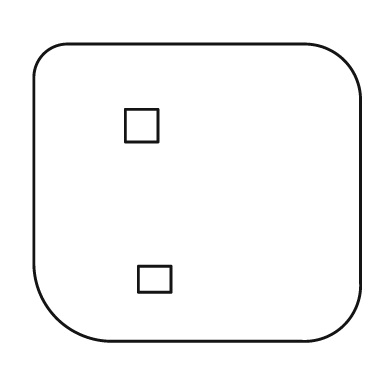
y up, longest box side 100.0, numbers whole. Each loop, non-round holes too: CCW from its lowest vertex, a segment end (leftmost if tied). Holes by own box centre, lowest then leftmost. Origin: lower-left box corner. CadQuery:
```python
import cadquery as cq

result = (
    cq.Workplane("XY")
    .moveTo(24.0, 0.0)
    .lineTo(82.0, 0.0)
    .threePointArc((95.0, 5.0), (100.0, 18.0))
    .lineTo(100.0, 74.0)
    .threePointArc((95.0, 86.0), (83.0, 91.0))
    .lineTo(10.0, 91.0)
    .threePointArc((3.0, 88.0), (0.0, 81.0))
    .lineTo(0.0, 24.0)
    .threePointArc((7.0, 7.0), (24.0, 0.0))
    .close()
    .moveTo(32.0, 15.0)
    .lineTo(42.0, 15.0)
    .lineTo(42.0, 23.0)
    .lineTo(32.0, 23.0)
    .close()
    .moveTo(28.0, 61.0)
    .lineTo(38.0, 61.0)
    .lineTo(38.0, 71.0)
    .lineTo(28.0, 71.0)
    .close()
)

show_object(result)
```